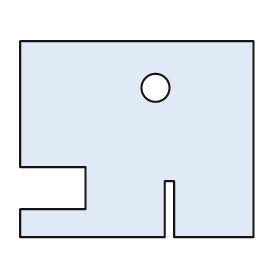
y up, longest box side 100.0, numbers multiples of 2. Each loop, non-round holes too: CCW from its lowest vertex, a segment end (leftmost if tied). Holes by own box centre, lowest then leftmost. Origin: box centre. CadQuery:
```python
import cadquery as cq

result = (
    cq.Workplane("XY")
    .moveTo(-50.0, -42.0)
    .lineTo(12.0, -42.0)
    .lineTo(12.0, -18.0)
    .lineTo(16.0, -18.0)
    .lineTo(16.0, -42.0)
    .lineTo(50.0, -42.0)
    .lineTo(50.0, 42.0)
    .lineTo(-50.0, 42.0)
    .lineTo(-50.0, -12.0)
    .lineTo(-22.0, -12.0)
    .lineTo(-22.0, -30.0)
    .lineTo(-50.0, -30.0)
    .close()
    .moveTo(8.0, 22.0)
    .circle(6.0)
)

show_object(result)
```